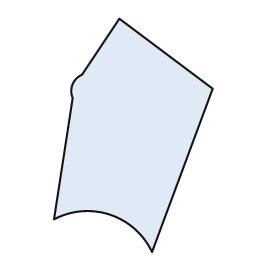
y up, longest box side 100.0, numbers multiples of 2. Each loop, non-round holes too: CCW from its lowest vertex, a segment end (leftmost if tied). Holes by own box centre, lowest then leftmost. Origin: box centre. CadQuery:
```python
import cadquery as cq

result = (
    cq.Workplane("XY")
    .moveTo(8.0, -50.0)
    .lineTo(34.0, 20.0)
    .lineTo(-6.0, 50.0)
    .lineTo(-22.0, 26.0)
    .threePointArc((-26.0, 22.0), (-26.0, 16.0))
    .lineTo(-34.0, -36.0)
    .threePointArc((-10.0, -34.0), (8.0, -50.0))
    .close()
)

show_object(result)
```